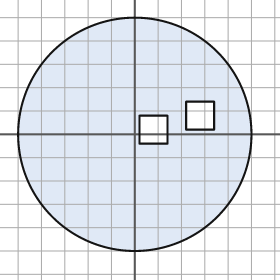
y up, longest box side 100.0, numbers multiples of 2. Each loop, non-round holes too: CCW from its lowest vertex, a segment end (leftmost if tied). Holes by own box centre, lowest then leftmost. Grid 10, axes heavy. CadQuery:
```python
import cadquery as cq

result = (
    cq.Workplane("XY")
    .moveTo(0.0, 0.0)
    .circle(50.0)
    .moveTo(2.0, -4.0)
    .lineTo(14.0, -4.0)
    .lineTo(14.0, 8.0)
    .lineTo(2.0, 8.0)
    .close()
    .moveTo(22.0, 2.0)
    .lineTo(34.0, 2.0)
    .lineTo(34.0, 14.0)
    .lineTo(22.0, 14.0)
    .close()
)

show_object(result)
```